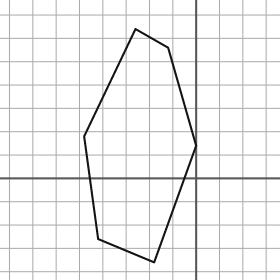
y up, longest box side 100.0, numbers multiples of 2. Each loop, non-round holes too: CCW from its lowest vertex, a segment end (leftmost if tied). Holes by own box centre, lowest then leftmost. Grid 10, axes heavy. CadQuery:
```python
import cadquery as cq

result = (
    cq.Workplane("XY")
    .moveTo(-18.0, -36.0)
    .lineTo(0.0, 14.0)
    .lineTo(-12.0, 56.0)
    .lineTo(-26.0, 64.0)
    .lineTo(-48.0, 18.0)
    .lineTo(-42.0, -26.0)
    .close()
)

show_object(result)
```